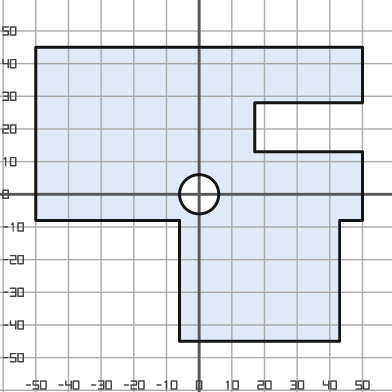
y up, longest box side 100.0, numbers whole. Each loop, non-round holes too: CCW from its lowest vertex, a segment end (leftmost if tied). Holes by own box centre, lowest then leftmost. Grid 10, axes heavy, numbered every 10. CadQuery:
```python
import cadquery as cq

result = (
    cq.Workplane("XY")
    .moveTo(-6.0, -45.0)
    .lineTo(43.0, -45.0)
    .lineTo(43.0, -8.0)
    .lineTo(50.0, -8.0)
    .lineTo(50.0, 13.0)
    .lineTo(17.0, 13.0)
    .lineTo(17.0, 28.0)
    .lineTo(50.0, 28.0)
    .lineTo(50.0, 45.0)
    .lineTo(-50.0, 45.0)
    .lineTo(-50.0, -8.0)
    .lineTo(-6.0, -8.0)
    .close()
    .moveTo(0.0, 0.0)
    .circle(6.0)
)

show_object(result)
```